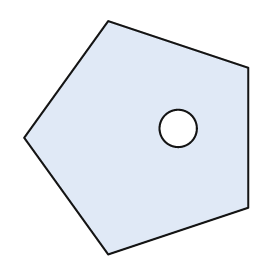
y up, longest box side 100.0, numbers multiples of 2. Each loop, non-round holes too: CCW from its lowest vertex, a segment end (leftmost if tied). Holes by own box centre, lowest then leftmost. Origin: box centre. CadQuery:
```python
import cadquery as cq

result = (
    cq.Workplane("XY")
    .moveTo(-12.0, -50.0)
    .lineTo(48.0, -30.0)
    .lineTo(48.0, 30.0)
    .lineTo(-12.0, 50.0)
    .lineTo(-48.0, 0.0)
    .close()
    .moveTo(18.0, 4.0)
    .circle(8.0)
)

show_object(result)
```